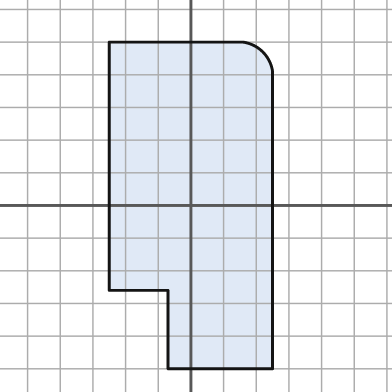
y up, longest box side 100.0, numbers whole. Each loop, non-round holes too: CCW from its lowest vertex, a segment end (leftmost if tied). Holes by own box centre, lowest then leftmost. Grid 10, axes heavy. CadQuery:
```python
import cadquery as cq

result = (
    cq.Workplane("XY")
    .moveTo(-7.0, -50.0)
    .lineTo(25.0, -50.0)
    .lineTo(25.0, 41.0)
    .threePointArc((22.0, 47.0), (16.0, 50.0))
    .lineTo(-25.0, 50.0)
    .lineTo(-25.0, -26.0)
    .lineTo(-7.0, -26.0)
    .close()
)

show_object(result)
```